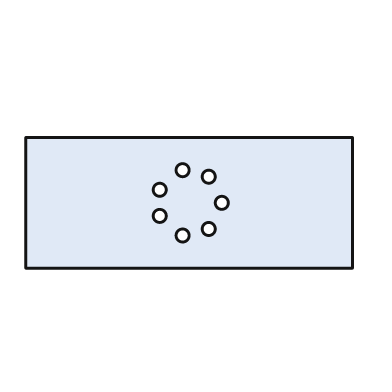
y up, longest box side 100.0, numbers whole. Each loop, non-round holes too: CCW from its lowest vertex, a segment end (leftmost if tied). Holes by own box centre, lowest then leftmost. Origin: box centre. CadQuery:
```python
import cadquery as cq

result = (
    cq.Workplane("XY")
    .moveTo(-50.0, -20.0)
    .lineTo(50.0, -20.0)
    .lineTo(50.0, 20.0)
    .lineTo(-50.0, 20.0)
    .close()
    .moveTo(-2.0, -10.0)
    .circle(2.0)
    .moveTo(6.0, -8.0)
    .circle(2.0)
    .moveTo(-9.0, -4.0)
    .circle(2.0)
    .moveTo(10.0, 0.0)
    .circle(2.0)
    .moveTo(-9.0, 4.0)
    .circle(2.0)
    .moveTo(6.0, 8.0)
    .circle(2.0)
    .moveTo(-2.0, 10.0)
    .circle(2.0)
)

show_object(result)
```